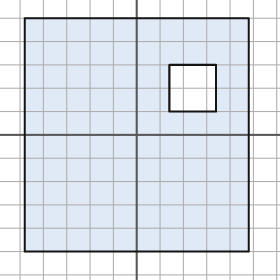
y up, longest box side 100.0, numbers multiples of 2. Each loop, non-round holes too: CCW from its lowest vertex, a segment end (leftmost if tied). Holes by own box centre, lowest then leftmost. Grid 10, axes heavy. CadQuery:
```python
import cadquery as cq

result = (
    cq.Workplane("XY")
    .moveTo(-48.0, -50.0)
    .lineTo(48.0, -50.0)
    .lineTo(48.0, 50.0)
    .lineTo(-48.0, 50.0)
    .close()
    .moveTo(14.0, 10.0)
    .lineTo(34.0, 10.0)
    .lineTo(34.0, 30.0)
    .lineTo(14.0, 30.0)
    .close()
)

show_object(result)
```